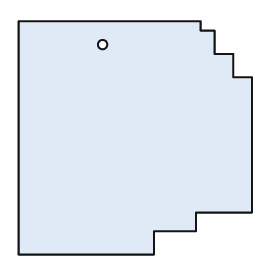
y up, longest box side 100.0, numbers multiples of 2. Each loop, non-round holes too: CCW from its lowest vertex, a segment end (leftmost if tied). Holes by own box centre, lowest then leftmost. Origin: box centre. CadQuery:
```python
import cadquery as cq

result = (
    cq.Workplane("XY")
    .moveTo(-50.0, -50.0)
    .lineTo(8.0, -50.0)
    .lineTo(8.0, -40.0)
    .lineTo(26.0, -40.0)
    .lineTo(26.0, -32.0)
    .lineTo(50.0, -32.0)
    .lineTo(50.0, 26.0)
    .lineTo(42.0, 26.0)
    .lineTo(42.0, 36.0)
    .lineTo(34.0, 36.0)
    .lineTo(34.0, 46.0)
    .lineTo(28.0, 46.0)
    .lineTo(28.0, 50.0)
    .lineTo(-50.0, 50.0)
    .close()
    .moveTo(-14.0, 40.0)
    .circle(2.0)
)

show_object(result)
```